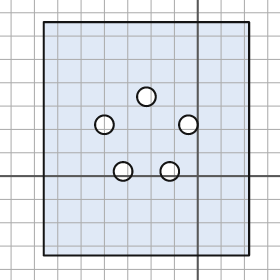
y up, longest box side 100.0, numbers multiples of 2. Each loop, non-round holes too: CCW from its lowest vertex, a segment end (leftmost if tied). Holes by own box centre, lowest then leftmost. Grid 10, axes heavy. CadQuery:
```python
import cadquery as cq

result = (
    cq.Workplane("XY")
    .moveTo(-66.0, -34.0)
    .lineTo(22.0, -34.0)
    .lineTo(22.0, 66.0)
    .lineTo(-66.0, 66.0)
    .close()
    .moveTo(-32.0, 2.0)
    .circle(4.0)
    .moveTo(-12.0, 2.0)
    .circle(4.0)
    .moveTo(-40.0, 22.0)
    .circle(4.0)
    .moveTo(-4.0, 22.0)
    .circle(4.0)
    .moveTo(-22.0, 34.0)
    .circle(4.0)
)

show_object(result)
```